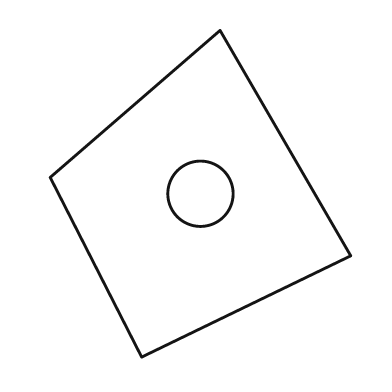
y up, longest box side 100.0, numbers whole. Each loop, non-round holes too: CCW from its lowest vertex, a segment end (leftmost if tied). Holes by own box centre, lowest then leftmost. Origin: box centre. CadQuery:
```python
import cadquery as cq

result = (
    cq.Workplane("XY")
    .moveTo(-18.0, -50.0)
    .lineTo(46.0, -19.0)
    .lineTo(6.0, 50.0)
    .lineTo(-46.0, 5.0)
    .close()
    .moveTo(0.0, 0.0)
    .circle(10.0)
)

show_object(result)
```